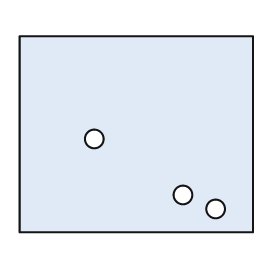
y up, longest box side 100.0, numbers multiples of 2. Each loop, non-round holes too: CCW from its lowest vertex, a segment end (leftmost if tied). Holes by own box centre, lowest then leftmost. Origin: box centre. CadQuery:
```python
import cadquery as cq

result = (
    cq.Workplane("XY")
    .moveTo(-50.0, -42.0)
    .lineTo(50.0, -42.0)
    .lineTo(50.0, 42.0)
    .lineTo(-50.0, 42.0)
    .close()
    .moveTo(34.0, -32.0)
    .circle(4.0)
    .moveTo(20.0, -26.0)
    .circle(4.0)
    .moveTo(-18.0, -2.0)
    .circle(4.0)
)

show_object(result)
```